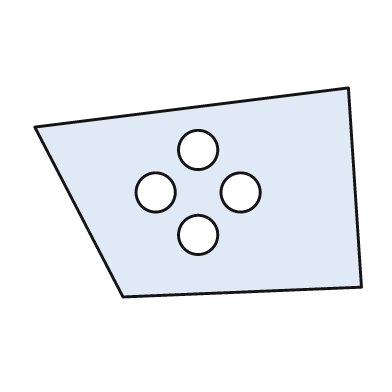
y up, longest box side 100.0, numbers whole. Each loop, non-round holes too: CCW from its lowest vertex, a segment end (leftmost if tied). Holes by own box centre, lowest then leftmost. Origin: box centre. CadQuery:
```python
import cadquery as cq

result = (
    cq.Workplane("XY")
    .moveTo(-23.0, -32.0)
    .lineTo(50.0, -29.0)
    .lineTo(46.0, 32.0)
    .lineTo(-50.0, 20.0)
    .close()
    .moveTo(0.0, -13.0)
    .circle(6.0)
    .moveTo(-13.0, 0.0)
    .circle(6.0)
    .moveTo(13.0, 0.0)
    .circle(6.0)
    .moveTo(0.0, 13.0)
    .circle(6.0)
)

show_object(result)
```